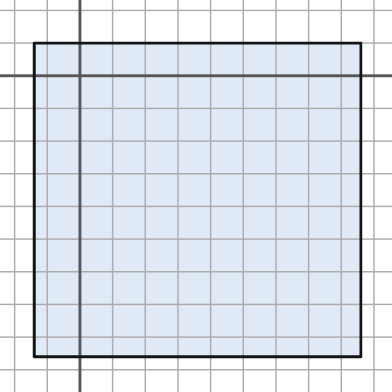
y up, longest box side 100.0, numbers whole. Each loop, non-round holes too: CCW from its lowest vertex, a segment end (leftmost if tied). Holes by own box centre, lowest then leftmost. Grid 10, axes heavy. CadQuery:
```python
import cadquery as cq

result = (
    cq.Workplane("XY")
    .moveTo(-14.0, -86.0)
    .lineTo(86.0, -86.0)
    .lineTo(86.0, 10.0)
    .lineTo(-14.0, 10.0)
    .close()
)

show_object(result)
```